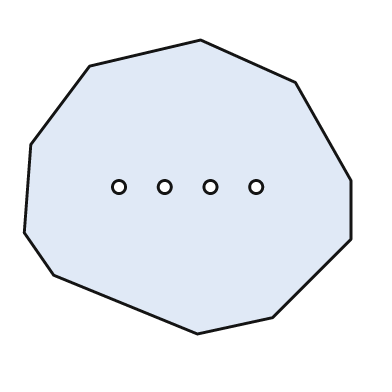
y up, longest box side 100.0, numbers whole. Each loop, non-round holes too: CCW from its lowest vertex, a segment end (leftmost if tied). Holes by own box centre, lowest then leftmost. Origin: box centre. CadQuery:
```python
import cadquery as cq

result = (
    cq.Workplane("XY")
    .moveTo(3.0, -45.0)
    .lineTo(26.0, -40.0)
    .lineTo(50.0, -16.0)
    .lineTo(50.0, 2.0)
    .lineTo(33.0, 32.0)
    .lineTo(4.0, 45.0)
    .lineTo(-30.0, 37.0)
    .lineTo(-48.0, 13.0)
    .lineTo(-50.0, -14.0)
    .lineTo(-41.0, -27.0)
    .close()
    .moveTo(-21.0, 0.0)
    .circle(2.0)
    .moveTo(-7.0, 0.0)
    .circle(2.0)
    .moveTo(7.0, 0.0)
    .circle(2.0)
    .moveTo(21.0, 0.0)
    .circle(2.0)
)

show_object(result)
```